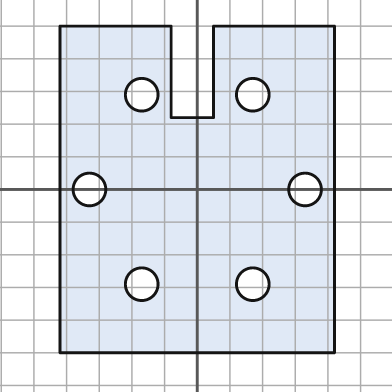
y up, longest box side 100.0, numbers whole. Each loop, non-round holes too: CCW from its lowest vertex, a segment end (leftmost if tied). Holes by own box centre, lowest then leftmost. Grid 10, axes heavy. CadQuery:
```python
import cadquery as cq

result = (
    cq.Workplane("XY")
    .moveTo(-42.0, -50.0)
    .lineTo(42.0, -50.0)
    .lineTo(42.0, 50.0)
    .lineTo(5.0, 50.0)
    .lineTo(5.0, 22.0)
    .lineTo(-8.0, 22.0)
    .lineTo(-8.0, 50.0)
    .lineTo(-42.0, 50.0)
    .close()
    .moveTo(-17.0, -29.0)
    .circle(5.0)
    .moveTo(17.0, -29.0)
    .circle(5.0)
    .moveTo(-33.0, 0.0)
    .circle(5.0)
    .moveTo(33.0, 0.0)
    .circle(5.0)
    .moveTo(-17.0, 29.0)
    .circle(5.0)
    .moveTo(17.0, 29.0)
    .circle(5.0)
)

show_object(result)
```